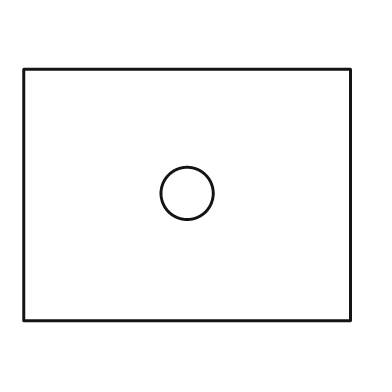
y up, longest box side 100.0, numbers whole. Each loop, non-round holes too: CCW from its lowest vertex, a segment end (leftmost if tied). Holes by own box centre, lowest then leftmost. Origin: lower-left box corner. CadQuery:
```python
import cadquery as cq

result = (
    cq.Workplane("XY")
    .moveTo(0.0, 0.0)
    .lineTo(100.0, 0.0)
    .lineTo(100.0, 77.0)
    .lineTo(0.0, 77.0)
    .close()
    .moveTo(50.0, 39.0)
    .circle(8.0)
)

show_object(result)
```